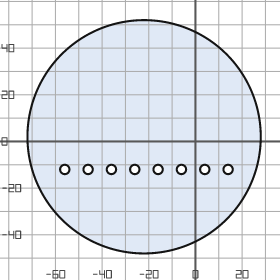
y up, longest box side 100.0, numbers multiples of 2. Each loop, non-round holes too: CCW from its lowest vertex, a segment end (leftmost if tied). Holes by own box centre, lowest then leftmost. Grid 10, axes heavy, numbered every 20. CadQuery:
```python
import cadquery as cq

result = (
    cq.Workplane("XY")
    .moveTo(-22.0, 2.0)
    .circle(50.0)
    .moveTo(-56.0, -12.0)
    .circle(2.0)
    .moveTo(-46.0, -12.0)
    .circle(2.0)
    .moveTo(-36.0, -12.0)
    .circle(2.0)
    .moveTo(-26.0, -12.0)
    .circle(2.0)
    .moveTo(-16.0, -12.0)
    .circle(2.0)
    .moveTo(-6.0, -12.0)
    .circle(2.0)
    .moveTo(4.0, -12.0)
    .circle(2.0)
    .moveTo(14.0, -12.0)
    .circle(2.0)
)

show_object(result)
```